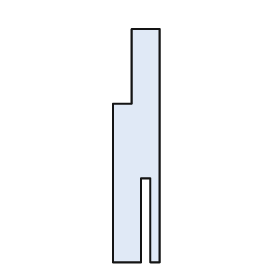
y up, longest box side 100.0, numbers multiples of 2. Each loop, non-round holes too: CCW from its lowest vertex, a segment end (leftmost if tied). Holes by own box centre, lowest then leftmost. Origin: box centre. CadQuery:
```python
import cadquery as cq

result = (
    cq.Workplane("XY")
    .moveTo(-10.0, -50.0)
    .lineTo(2.0, -50.0)
    .lineTo(2.0, -14.0)
    .lineTo(6.0, -14.0)
    .lineTo(6.0, -50.0)
    .lineTo(10.0, -50.0)
    .lineTo(10.0, 50.0)
    .lineTo(-2.0, 50.0)
    .lineTo(-2.0, 18.0)
    .lineTo(-10.0, 18.0)
    .close()
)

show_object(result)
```